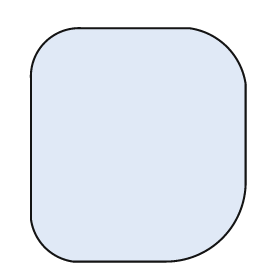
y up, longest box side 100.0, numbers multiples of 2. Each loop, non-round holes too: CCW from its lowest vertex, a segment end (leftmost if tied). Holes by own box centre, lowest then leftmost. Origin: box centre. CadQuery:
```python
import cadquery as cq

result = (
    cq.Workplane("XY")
    .moveTo(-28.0, -50.0)
    .lineTo(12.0, -50.0)
    .threePointArc((36.0, -40.0), (46.0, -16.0))
    .lineTo(46.0, 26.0)
    .threePointArc((38.0, 42.0), (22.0, 50.0))
    .lineTo(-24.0, 50.0)
    .threePointArc((-40.0, 44.0), (-46.0, 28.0))
    .lineTo(-46.0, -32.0)
    .threePointArc((-40.0, -44.0), (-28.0, -50.0))
    .close()
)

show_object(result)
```